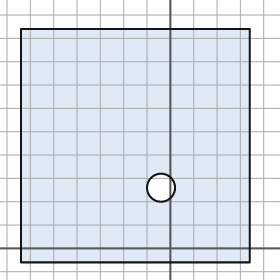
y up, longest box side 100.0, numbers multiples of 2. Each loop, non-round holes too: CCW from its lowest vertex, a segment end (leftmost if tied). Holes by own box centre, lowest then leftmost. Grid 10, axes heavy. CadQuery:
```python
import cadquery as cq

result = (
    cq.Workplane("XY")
    .moveTo(-64.0, -6.0)
    .lineTo(34.0, -6.0)
    .lineTo(34.0, 94.0)
    .lineTo(-64.0, 94.0)
    .close()
    .moveTo(-4.0, 26.0)
    .circle(6.0)
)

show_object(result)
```